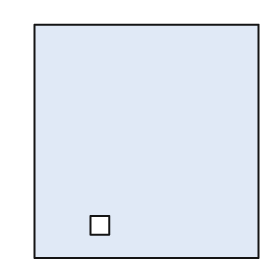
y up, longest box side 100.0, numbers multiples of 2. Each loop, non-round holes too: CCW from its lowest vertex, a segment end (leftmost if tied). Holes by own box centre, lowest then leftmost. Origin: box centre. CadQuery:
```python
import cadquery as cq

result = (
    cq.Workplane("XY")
    .moveTo(-48.0, -50.0)
    .lineTo(48.0, -50.0)
    .lineTo(48.0, 50.0)
    .lineTo(-48.0, 50.0)
    .close()
    .moveTo(-24.0, -40.0)
    .lineTo(-16.0, -40.0)
    .lineTo(-16.0, -32.0)
    .lineTo(-24.0, -32.0)
    .close()
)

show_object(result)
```